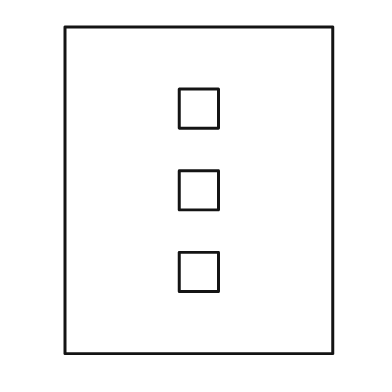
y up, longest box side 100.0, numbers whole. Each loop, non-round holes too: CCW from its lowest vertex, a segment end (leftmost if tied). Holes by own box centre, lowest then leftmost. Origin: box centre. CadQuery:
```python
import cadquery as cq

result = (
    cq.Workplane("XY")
    .moveTo(-41.0, -50.0)
    .lineTo(41.0, -50.0)
    .lineTo(41.0, 50.0)
    .lineTo(-41.0, 50.0)
    .close()
    .moveTo(-6.0, -31.0)
    .lineTo(6.0, -31.0)
    .lineTo(6.0, -19.0)
    .lineTo(-6.0, -19.0)
    .close()
    .moveTo(-6.0, -6.0)
    .lineTo(6.0, -6.0)
    .lineTo(6.0, 6.0)
    .lineTo(-6.0, 6.0)
    .close()
    .moveTo(-6.0, 19.0)
    .lineTo(6.0, 19.0)
    .lineTo(6.0, 31.0)
    .lineTo(-6.0, 31.0)
    .close()
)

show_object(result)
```